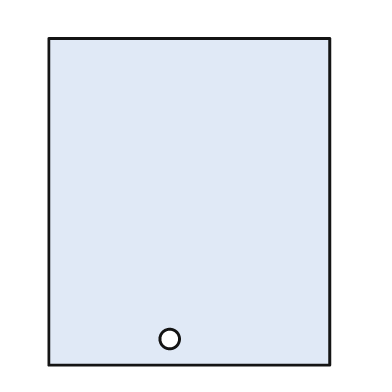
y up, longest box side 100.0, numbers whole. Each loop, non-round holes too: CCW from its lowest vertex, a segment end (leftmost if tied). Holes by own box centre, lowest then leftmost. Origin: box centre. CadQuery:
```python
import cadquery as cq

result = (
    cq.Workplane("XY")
    .moveTo(-43.0, -50.0)
    .lineTo(43.0, -50.0)
    .lineTo(43.0, 50.0)
    .lineTo(-43.0, 50.0)
    .close()
    .moveTo(-6.0, -42.0)
    .circle(3.0)
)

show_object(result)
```